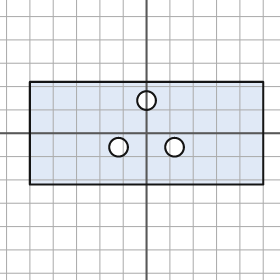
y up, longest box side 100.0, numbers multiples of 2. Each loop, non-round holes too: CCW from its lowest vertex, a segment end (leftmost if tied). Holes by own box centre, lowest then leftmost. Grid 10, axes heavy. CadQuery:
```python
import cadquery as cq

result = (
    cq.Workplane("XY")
    .moveTo(-50.0, -22.0)
    .lineTo(50.0, -22.0)
    .lineTo(50.0, 22.0)
    .lineTo(-50.0, 22.0)
    .close()
    .moveTo(-12.0, -6.0)
    .circle(4.0)
    .moveTo(12.0, -6.0)
    .circle(4.0)
    .moveTo(0.0, 14.0)
    .circle(4.0)
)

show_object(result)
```